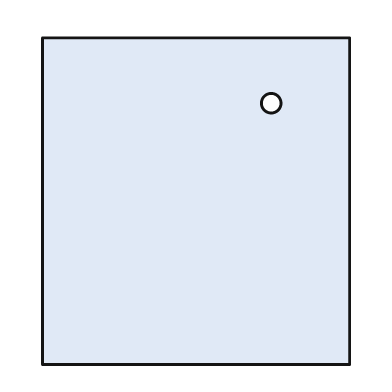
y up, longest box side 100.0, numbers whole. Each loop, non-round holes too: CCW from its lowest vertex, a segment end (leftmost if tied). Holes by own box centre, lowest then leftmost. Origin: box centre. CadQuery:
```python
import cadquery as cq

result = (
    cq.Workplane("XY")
    .moveTo(-47.0, -50.0)
    .lineTo(47.0, -50.0)
    .lineTo(47.0, 50.0)
    .lineTo(-47.0, 50.0)
    .close()
    .moveTo(23.0, 30.0)
    .circle(3.0)
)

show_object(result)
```